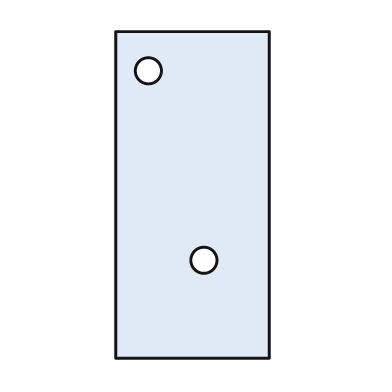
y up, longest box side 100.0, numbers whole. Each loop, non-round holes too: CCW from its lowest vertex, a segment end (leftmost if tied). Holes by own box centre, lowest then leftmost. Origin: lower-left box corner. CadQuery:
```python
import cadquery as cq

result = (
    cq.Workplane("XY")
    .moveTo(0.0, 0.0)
    .lineTo(47.0, 0.0)
    .lineTo(47.0, 100.0)
    .lineTo(0.0, 100.0)
    .close()
    .moveTo(27.0, 30.0)
    .circle(4.0)
    .moveTo(10.0, 88.0)
    .circle(4.0)
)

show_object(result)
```